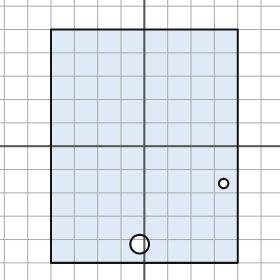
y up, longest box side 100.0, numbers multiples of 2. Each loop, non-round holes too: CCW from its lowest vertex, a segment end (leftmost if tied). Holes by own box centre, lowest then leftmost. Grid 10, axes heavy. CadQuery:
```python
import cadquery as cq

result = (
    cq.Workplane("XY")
    .moveTo(-40.0, -50.0)
    .lineTo(40.0, -50.0)
    .lineTo(40.0, 50.0)
    .lineTo(-40.0, 50.0)
    .close()
    .moveTo(-2.0, -42.0)
    .circle(4.0)
    .moveTo(34.0, -16.0)
    .circle(2.0)
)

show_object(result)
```